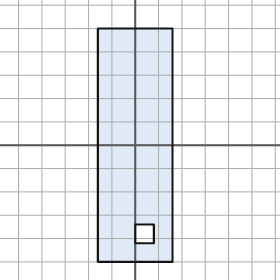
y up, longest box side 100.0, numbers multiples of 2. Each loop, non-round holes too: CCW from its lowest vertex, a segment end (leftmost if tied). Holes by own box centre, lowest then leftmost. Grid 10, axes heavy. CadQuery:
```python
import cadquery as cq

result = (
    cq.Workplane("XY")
    .moveTo(-16.0, -50.0)
    .lineTo(16.0, -50.0)
    .lineTo(16.0, 50.0)
    .lineTo(-16.0, 50.0)
    .close()
    .moveTo(0.0, -42.0)
    .lineTo(8.0, -42.0)
    .lineTo(8.0, -34.0)
    .lineTo(0.0, -34.0)
    .close()
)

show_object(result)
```